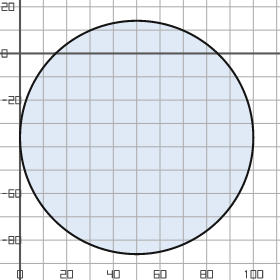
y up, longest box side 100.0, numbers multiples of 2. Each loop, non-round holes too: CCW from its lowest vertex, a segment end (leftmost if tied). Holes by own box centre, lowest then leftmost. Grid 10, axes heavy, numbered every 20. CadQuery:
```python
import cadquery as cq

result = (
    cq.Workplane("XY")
    .moveTo(50.0, -36.0)
    .circle(50.0)
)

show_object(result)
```